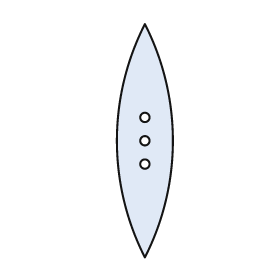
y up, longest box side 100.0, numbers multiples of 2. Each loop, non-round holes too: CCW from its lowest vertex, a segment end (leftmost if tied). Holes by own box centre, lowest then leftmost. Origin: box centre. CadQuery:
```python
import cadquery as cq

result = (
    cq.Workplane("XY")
    .moveTo(0.0, -50.0)
    .threePointArc((12.0, 0.0), (0.0, 50.0))
    .threePointArc((-12.0, 0.0), (0.0, -50.0))
    .close()
    .moveTo(0.0, -10.0)
    .circle(2.0)
    .moveTo(0.0, 0.0)
    .circle(2.0)
    .moveTo(0.0, 10.0)
    .circle(2.0)
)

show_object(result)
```